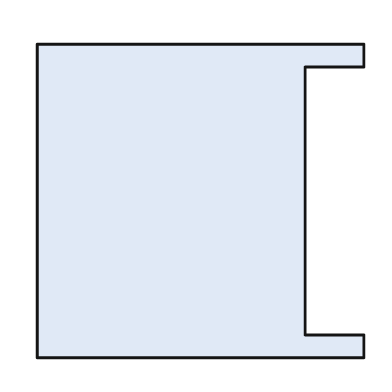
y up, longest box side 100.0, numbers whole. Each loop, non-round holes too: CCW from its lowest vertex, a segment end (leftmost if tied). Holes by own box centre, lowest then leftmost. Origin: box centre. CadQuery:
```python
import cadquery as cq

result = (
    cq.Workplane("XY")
    .moveTo(-50.0, -48.0)
    .lineTo(50.0, -48.0)
    .lineTo(50.0, -41.0)
    .lineTo(32.0, -41.0)
    .lineTo(32.0, 41.0)
    .lineTo(50.0, 41.0)
    .lineTo(50.0, 48.0)
    .lineTo(-50.0, 48.0)
    .close()
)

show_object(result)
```